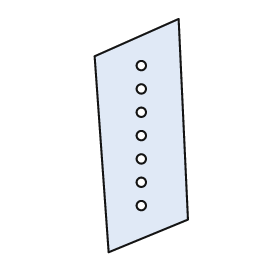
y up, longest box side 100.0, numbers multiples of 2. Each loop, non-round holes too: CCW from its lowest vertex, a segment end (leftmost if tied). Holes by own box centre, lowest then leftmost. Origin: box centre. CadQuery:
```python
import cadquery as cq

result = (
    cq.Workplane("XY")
    .moveTo(-14.0, -50.0)
    .lineTo(20.0, -36.0)
    .lineTo(16.0, 50.0)
    .lineTo(-20.0, 34.0)
    .close()
    .moveTo(0.0, -30.0)
    .circle(2.0)
    .moveTo(0.0, -20.0)
    .circle(2.0)
    .moveTo(0.0, -10.0)
    .circle(2.0)
    .moveTo(0.0, 0.0)
    .circle(2.0)
    .moveTo(0.0, 10.0)
    .circle(2.0)
    .moveTo(0.0, 20.0)
    .circle(2.0)
    .moveTo(0.0, 30.0)
    .circle(2.0)
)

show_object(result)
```